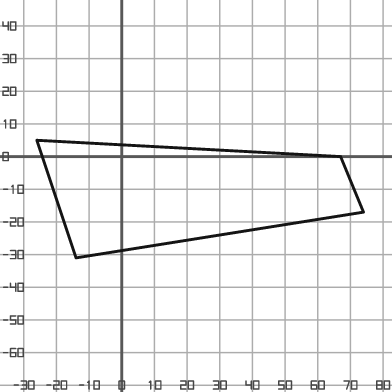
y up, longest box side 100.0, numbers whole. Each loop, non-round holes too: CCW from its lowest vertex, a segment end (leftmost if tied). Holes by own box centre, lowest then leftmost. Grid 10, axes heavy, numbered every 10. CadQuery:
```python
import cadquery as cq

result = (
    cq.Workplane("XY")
    .moveTo(-14.0, -31.0)
    .lineTo(74.0, -17.0)
    .lineTo(67.0, 0.0)
    .lineTo(-26.0, 5.0)
    .close()
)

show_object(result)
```